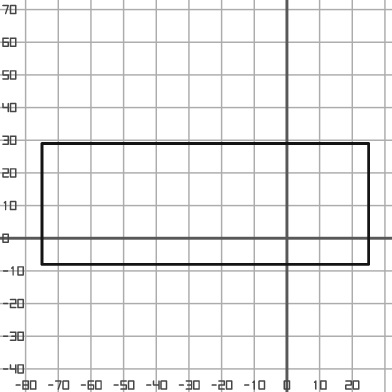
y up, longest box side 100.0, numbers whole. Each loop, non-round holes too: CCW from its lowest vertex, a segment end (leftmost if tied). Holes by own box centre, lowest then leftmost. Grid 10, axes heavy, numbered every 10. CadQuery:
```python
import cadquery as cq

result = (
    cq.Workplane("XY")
    .moveTo(-75.0, -8.0)
    .lineTo(25.0, -8.0)
    .lineTo(25.0, 29.0)
    .lineTo(-75.0, 29.0)
    .close()
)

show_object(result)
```